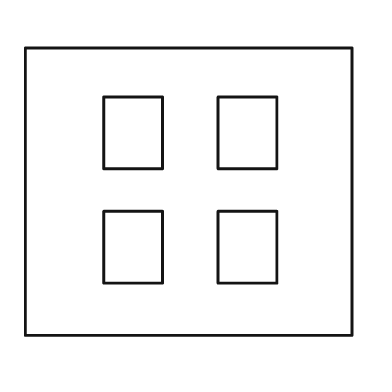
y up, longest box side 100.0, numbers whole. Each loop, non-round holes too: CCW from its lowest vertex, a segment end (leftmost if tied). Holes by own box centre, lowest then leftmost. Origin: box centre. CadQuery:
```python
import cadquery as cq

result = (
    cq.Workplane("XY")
    .moveTo(-50.0, -44.0)
    .lineTo(50.0, -44.0)
    .lineTo(50.0, 44.0)
    .lineTo(-50.0, 44.0)
    .close()
    .moveTo(-26.0, -28.0)
    .lineTo(-8.0, -28.0)
    .lineTo(-8.0, -6.0)
    .lineTo(-26.0, -6.0)
    .close()
    .moveTo(9.0, -28.0)
    .lineTo(27.0, -28.0)
    .lineTo(27.0, -6.0)
    .lineTo(9.0, -6.0)
    .close()
    .moveTo(-26.0, 7.0)
    .lineTo(-8.0, 7.0)
    .lineTo(-8.0, 29.0)
    .lineTo(-26.0, 29.0)
    .close()
    .moveTo(9.0, 7.0)
    .lineTo(27.0, 7.0)
    .lineTo(27.0, 29.0)
    .lineTo(9.0, 29.0)
    .close()
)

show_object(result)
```